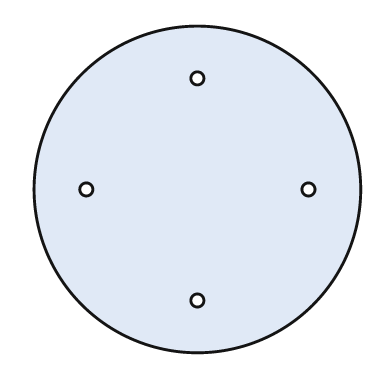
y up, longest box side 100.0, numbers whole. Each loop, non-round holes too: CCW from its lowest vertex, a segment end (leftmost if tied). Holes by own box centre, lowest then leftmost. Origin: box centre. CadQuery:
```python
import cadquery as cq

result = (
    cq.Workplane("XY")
    .moveTo(0.0, 0.0)
    .circle(50.0)
    .moveTo(0.0, -34.0)
    .circle(2.0)
    .moveTo(-34.0, 0.0)
    .circle(2.0)
    .moveTo(34.0, 0.0)
    .circle(2.0)
    .moveTo(0.0, 34.0)
    .circle(2.0)
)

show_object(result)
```